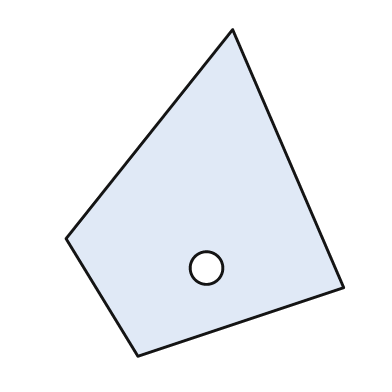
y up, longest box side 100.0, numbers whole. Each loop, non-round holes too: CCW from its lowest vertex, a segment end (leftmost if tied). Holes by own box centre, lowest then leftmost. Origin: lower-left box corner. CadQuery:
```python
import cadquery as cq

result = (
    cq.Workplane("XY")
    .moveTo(22.0, 0.0)
    .lineTo(85.0, 21.0)
    .lineTo(51.0, 100.0)
    .lineTo(0.0, 36.0)
    .close()
    .moveTo(43.0, 27.0)
    .circle(5.0)
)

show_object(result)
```